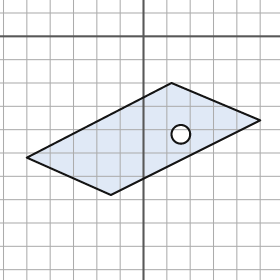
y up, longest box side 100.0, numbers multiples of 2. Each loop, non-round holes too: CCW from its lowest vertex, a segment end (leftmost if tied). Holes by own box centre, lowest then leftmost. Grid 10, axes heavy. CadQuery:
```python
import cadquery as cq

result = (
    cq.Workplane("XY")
    .moveTo(-14.0, -68.0)
    .lineTo(50.0, -36.0)
    .lineTo(12.0, -20.0)
    .lineTo(-50.0, -52.0)
    .close()
    .moveTo(16.0, -42.0)
    .circle(4.0)
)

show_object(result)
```